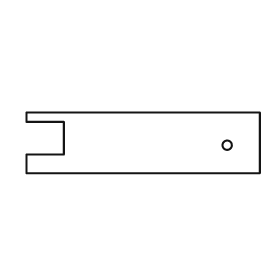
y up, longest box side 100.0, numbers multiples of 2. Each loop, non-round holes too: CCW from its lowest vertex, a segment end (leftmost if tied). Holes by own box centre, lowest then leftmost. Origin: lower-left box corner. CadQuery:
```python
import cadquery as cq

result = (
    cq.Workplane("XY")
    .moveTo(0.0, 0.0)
    .lineTo(100.0, 0.0)
    .lineTo(100.0, 26.0)
    .lineTo(0.0, 26.0)
    .lineTo(0.0, 22.0)
    .lineTo(16.0, 22.0)
    .lineTo(16.0, 8.0)
    .lineTo(0.0, 8.0)
    .close()
    .moveTo(86.0, 12.0)
    .circle(2.0)
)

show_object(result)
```